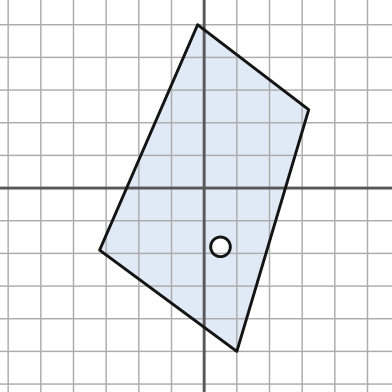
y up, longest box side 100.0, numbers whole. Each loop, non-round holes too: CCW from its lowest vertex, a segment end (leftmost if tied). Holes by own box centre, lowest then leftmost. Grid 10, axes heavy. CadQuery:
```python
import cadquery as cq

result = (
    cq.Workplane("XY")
    .moveTo(10.0, -50.0)
    .lineTo(32.0, 24.0)
    .lineTo(-2.0, 50.0)
    .lineTo(-32.0, -19.0)
    .close()
    .moveTo(5.0, -18.0)
    .circle(3.0)
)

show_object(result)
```